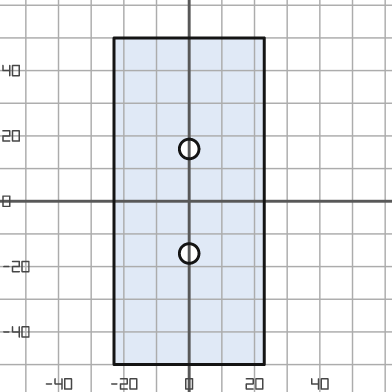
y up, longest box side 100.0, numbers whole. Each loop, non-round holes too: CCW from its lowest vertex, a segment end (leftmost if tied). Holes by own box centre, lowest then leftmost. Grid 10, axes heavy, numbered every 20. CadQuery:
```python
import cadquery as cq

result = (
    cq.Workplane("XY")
    .moveTo(-23.0, -50.0)
    .lineTo(23.0, -50.0)
    .lineTo(23.0, 50.0)
    .lineTo(-23.0, 50.0)
    .close()
    .moveTo(0.0, -16.0)
    .circle(3.0)
    .moveTo(0.0, 16.0)
    .circle(3.0)
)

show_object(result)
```